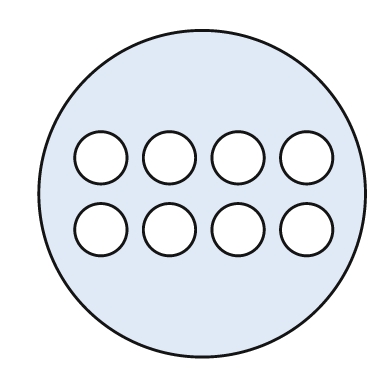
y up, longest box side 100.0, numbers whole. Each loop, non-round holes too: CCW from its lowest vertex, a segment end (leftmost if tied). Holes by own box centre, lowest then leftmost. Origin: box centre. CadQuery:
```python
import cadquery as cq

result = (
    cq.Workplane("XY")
    .moveTo(0.0, 0.0)
    .circle(50.0)
    .moveTo(-31.0, -11.0)
    .circle(8.0)
    .moveTo(-10.0, -11.0)
    .circle(8.0)
    .moveTo(11.0, -11.0)
    .circle(8.0)
    .moveTo(32.0, -11.0)
    .circle(8.0)
    .moveTo(-31.0, 11.0)
    .circle(8.0)
    .moveTo(-10.0, 11.0)
    .circle(8.0)
    .moveTo(11.0, 11.0)
    .circle(8.0)
    .moveTo(32.0, 11.0)
    .circle(8.0)
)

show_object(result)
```